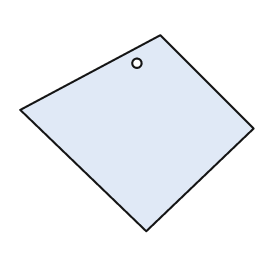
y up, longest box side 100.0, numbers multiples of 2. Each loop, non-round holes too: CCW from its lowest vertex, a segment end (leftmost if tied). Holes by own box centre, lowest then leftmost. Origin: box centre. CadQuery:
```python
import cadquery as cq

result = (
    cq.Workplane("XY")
    .moveTo(4.0, -42.0)
    .lineTo(50.0, 2.0)
    .lineTo(10.0, 42.0)
    .lineTo(-50.0, 10.0)
    .close()
    .moveTo(0.0, 30.0)
    .circle(2.0)
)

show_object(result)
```